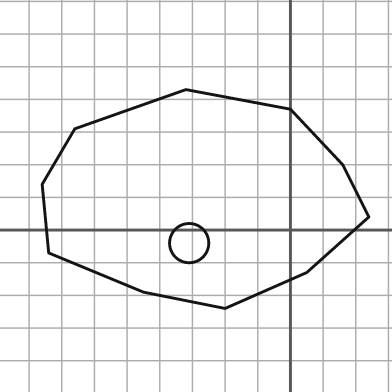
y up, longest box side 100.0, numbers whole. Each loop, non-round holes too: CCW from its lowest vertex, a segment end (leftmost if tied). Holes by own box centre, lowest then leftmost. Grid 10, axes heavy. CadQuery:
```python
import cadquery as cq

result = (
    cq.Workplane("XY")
    .moveTo(-20.0, -24.0)
    .lineTo(5.0, -13.0)
    .lineTo(24.0, 4.0)
    .lineTo(16.0, 20.0)
    .lineTo(0.0, 37.0)
    .lineTo(-32.0, 43.0)
    .lineTo(-66.0, 31.0)
    .lineTo(-76.0, 14.0)
    .lineTo(-74.0, -7.0)
    .lineTo(-45.0, -19.0)
    .close()
    .moveTo(-31.0, -4.0)
    .circle(6.0)
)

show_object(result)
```